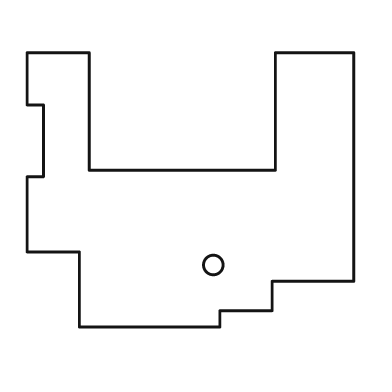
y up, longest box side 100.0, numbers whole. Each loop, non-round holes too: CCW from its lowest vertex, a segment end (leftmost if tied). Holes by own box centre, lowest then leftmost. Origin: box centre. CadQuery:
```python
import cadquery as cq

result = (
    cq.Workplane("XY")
    .moveTo(-34.0, -42.0)
    .lineTo(9.0, -42.0)
    .lineTo(9.0, -37.0)
    .lineTo(25.0, -37.0)
    .lineTo(25.0, -28.0)
    .lineTo(50.0, -28.0)
    .lineTo(50.0, 42.0)
    .lineTo(26.0, 42.0)
    .lineTo(26.0, 6.0)
    .lineTo(-31.0, 6.0)
    .lineTo(-31.0, 42.0)
    .lineTo(-50.0, 42.0)
    .lineTo(-50.0, 26.0)
    .lineTo(-45.0, 26.0)
    .lineTo(-45.0, 4.0)
    .lineTo(-50.0, 4.0)
    .lineTo(-50.0, -19.0)
    .lineTo(-34.0, -19.0)
    .close()
    .moveTo(7.0, -23.0)
    .circle(3.0)
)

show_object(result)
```